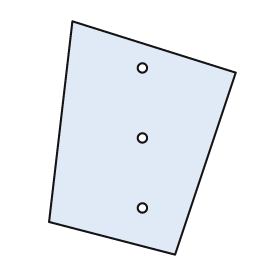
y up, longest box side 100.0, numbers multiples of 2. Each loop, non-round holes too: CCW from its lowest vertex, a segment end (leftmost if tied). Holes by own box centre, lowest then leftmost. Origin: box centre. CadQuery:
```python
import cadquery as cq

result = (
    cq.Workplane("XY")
    .moveTo(14.0, -50.0)
    .lineTo(40.0, 28.0)
    .lineTo(-30.0, 50.0)
    .lineTo(-40.0, -36.0)
    .close()
    .moveTo(0.0, -30.0)
    .circle(2.0)
    .moveTo(0.0, 0.0)
    .circle(2.0)
    .moveTo(0.0, 30.0)
    .circle(2.0)
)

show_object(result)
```